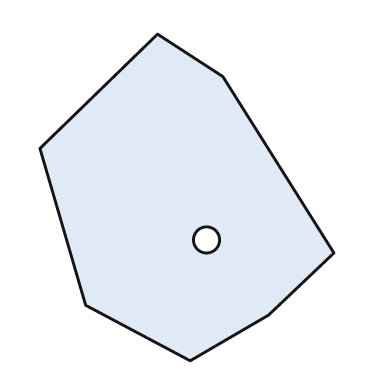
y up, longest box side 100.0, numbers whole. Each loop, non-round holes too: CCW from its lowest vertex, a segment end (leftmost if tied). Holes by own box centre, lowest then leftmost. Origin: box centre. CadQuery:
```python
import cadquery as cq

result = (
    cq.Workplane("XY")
    .moveTo(1.0, -50.0)
    .lineTo(25.0, -36.0)
    .lineTo(45.0, -17.0)
    .lineTo(11.0, 37.0)
    .lineTo(-9.0, 50.0)
    .lineTo(-45.0, 15.0)
    .lineTo(-31.0, -33.0)
    .close()
    .moveTo(6.0, -13.0)
    .circle(4.0)
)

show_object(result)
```